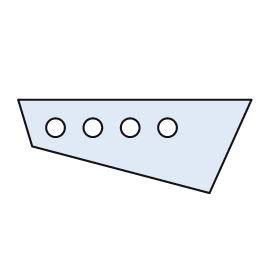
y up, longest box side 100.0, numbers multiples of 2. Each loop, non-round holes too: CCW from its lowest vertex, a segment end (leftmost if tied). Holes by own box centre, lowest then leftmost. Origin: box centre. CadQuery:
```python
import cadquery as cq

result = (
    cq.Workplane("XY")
    .moveTo(32.0, -20.0)
    .lineTo(50.0, 20.0)
    .lineTo(-50.0, 20.0)
    .lineTo(-44.0, 0.0)
    .close()
    .moveTo(-34.0, 8.0)
    .circle(4.0)
    .moveTo(-18.0, 8.0)
    .circle(4.0)
    .moveTo(-2.0, 8.0)
    .circle(4.0)
    .moveTo(14.0, 8.0)
    .circle(4.0)
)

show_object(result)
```